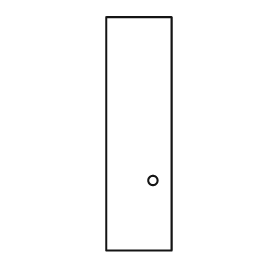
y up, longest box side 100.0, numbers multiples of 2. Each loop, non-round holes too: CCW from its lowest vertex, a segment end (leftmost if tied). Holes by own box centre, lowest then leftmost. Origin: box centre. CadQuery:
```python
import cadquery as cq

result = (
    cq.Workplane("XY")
    .moveTo(-14.0, -50.0)
    .lineTo(14.0, -50.0)
    .lineTo(14.0, 50.0)
    .lineTo(-14.0, 50.0)
    .close()
    .moveTo(6.0, -20.0)
    .circle(2.0)
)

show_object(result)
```